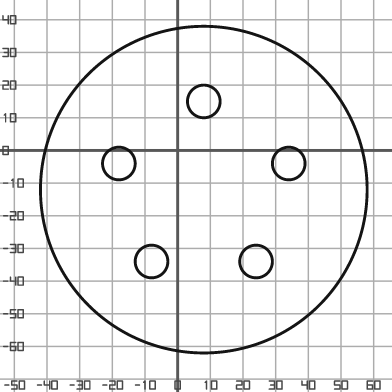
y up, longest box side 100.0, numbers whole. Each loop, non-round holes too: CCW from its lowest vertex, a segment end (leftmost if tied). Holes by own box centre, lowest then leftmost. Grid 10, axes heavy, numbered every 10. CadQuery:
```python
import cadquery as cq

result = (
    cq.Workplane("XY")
    .moveTo(8.0, -12.0)
    .circle(50.0)
    .moveTo(-8.0, -34.0)
    .circle(5.0)
    .moveTo(24.0, -34.0)
    .circle(5.0)
    .moveTo(-18.0, -4.0)
    .circle(5.0)
    .moveTo(34.0, -4.0)
    .circle(5.0)
    .moveTo(8.0, 15.0)
    .circle(5.0)
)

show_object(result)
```